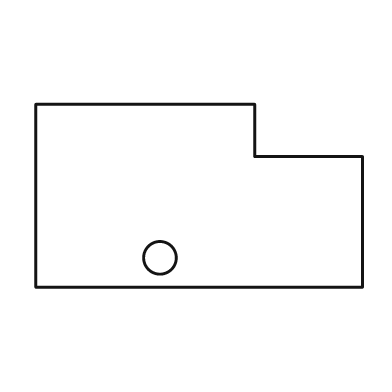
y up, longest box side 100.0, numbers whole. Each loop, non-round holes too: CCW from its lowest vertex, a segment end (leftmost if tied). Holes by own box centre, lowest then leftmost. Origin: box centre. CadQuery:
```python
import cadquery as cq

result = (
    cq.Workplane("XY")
    .moveTo(-50.0, -28.0)
    .lineTo(50.0, -28.0)
    .lineTo(50.0, 12.0)
    .lineTo(17.0, 12.0)
    .lineTo(17.0, 28.0)
    .lineTo(-50.0, 28.0)
    .close()
    .moveTo(-12.0, -19.0)
    .circle(5.0)
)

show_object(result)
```